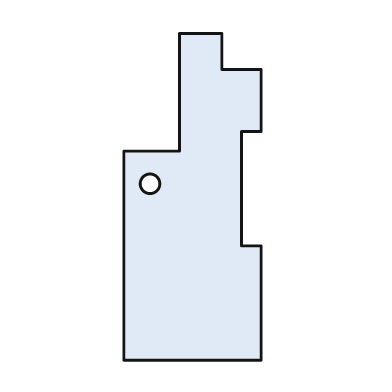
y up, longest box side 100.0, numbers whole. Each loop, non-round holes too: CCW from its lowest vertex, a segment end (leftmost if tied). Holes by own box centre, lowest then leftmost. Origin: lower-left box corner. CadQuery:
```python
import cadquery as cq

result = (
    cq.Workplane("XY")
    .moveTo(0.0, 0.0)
    .lineTo(42.0, 0.0)
    .lineTo(42.0, 35.0)
    .lineTo(36.0, 35.0)
    .lineTo(36.0, 70.0)
    .lineTo(42.0, 70.0)
    .lineTo(42.0, 89.0)
    .lineTo(30.0, 89.0)
    .lineTo(30.0, 100.0)
    .lineTo(17.0, 100.0)
    .lineTo(17.0, 64.0)
    .lineTo(0.0, 64.0)
    .close()
    .moveTo(8.0, 54.0)
    .circle(3.0)
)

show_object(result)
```